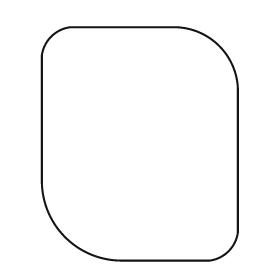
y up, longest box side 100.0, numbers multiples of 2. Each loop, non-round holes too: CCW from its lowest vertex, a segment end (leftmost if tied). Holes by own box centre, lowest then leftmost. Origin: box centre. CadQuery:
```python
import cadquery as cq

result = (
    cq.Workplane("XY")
    .moveTo(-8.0, -50.0)
    .lineTo(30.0, -50.0)
    .threePointArc((38.0, -46.0), (42.0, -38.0))
    .lineTo(42.0, 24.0)
    .threePointArc((34.0, 42.0), (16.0, 50.0))
    .lineTo(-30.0, 50.0)
    .threePointArc((-38.0, 46.0), (-42.0, 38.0))
    .lineTo(-42.0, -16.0)
    .threePointArc((-32.0, -40.0), (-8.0, -50.0))
    .close()
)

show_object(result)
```